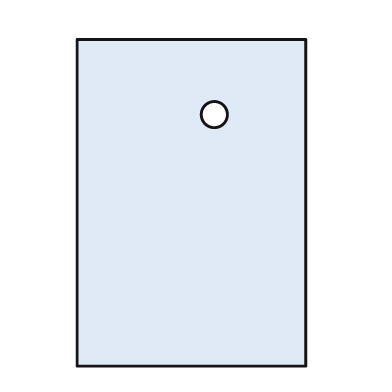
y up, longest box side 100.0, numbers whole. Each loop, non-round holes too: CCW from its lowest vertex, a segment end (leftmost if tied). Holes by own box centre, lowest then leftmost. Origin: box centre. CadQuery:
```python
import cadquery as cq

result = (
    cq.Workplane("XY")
    .moveTo(-35.0, -50.0)
    .lineTo(35.0, -50.0)
    .lineTo(35.0, 50.0)
    .lineTo(-35.0, 50.0)
    .close()
    .moveTo(7.0, 27.0)
    .circle(4.0)
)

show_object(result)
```